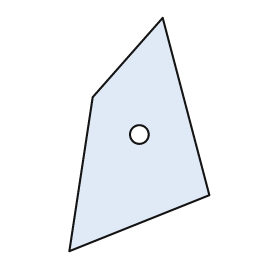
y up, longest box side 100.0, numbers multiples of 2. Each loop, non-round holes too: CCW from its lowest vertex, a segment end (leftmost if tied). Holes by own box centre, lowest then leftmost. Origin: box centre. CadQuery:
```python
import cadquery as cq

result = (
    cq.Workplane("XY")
    .moveTo(-30.0, -50.0)
    .lineTo(30.0, -26.0)
    .lineTo(10.0, 50.0)
    .lineTo(-20.0, 16.0)
    .close()
    .moveTo(0.0, 0.0)
    .circle(4.0)
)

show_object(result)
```